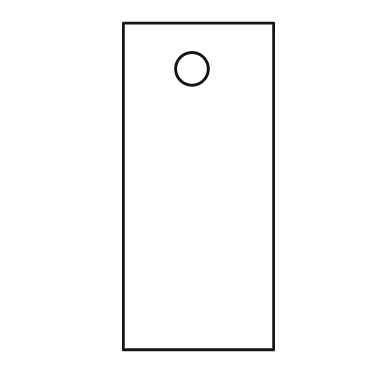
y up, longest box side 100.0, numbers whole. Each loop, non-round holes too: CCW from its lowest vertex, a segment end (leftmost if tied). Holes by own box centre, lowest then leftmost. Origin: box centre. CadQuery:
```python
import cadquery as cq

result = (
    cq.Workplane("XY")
    .moveTo(-23.0, -50.0)
    .lineTo(23.0, -50.0)
    .lineTo(23.0, 50.0)
    .lineTo(-23.0, 50.0)
    .close()
    .moveTo(-2.0, 36.0)
    .circle(5.0)
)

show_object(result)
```